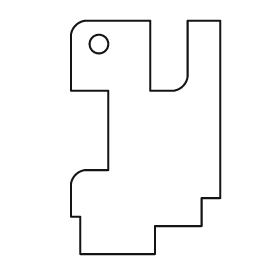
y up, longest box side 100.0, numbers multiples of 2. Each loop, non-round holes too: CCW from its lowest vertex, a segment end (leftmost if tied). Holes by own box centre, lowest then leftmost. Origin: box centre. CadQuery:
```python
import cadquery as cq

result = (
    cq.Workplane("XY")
    .moveTo(-28.0, -50.0)
    .lineTo(4.0, -50.0)
    .lineTo(4.0, -38.0)
    .lineTo(24.0, -38.0)
    .lineTo(24.0, -26.0)
    .lineTo(32.0, -26.0)
    .lineTo(32.0, 50.0)
    .lineTo(18.0, 50.0)
    .lineTo(18.0, 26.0)
    .threePointArc((16.0, 22.0), (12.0, 20.0))
    .lineTo(2.0, 20.0)
    .lineTo(2.0, 50.0)
    .lineTo(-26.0, 50.0)
    .threePointArc((-30.0, 48.0), (-32.0, 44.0))
    .lineTo(-32.0, 20.0)
    .lineTo(-16.0, 20.0)
    .lineTo(-16.0, -14.0)
    .lineTo(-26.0, -14.0)
    .threePointArc((-30.0, -16.0), (-32.0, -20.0))
    .lineTo(-32.0, -34.0)
    .lineTo(-28.0, -34.0)
    .close()
    .moveTo(-20.0, 40.0)
    .circle(4.0)
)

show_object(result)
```